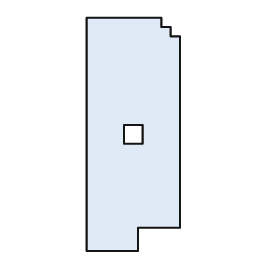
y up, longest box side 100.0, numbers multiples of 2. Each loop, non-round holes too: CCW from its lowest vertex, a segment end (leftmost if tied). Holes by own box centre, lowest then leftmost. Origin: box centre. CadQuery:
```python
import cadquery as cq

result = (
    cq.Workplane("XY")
    .moveTo(-20.0, -50.0)
    .lineTo(2.0, -50.0)
    .lineTo(2.0, -40.0)
    .lineTo(20.0, -40.0)
    .lineTo(20.0, 42.0)
    .lineTo(16.0, 42.0)
    .lineTo(16.0, 46.0)
    .lineTo(12.0, 46.0)
    .lineTo(12.0, 50.0)
    .lineTo(-20.0, 50.0)
    .close()
    .moveTo(-4.0, -4.0)
    .lineTo(4.0, -4.0)
    .lineTo(4.0, 4.0)
    .lineTo(-4.0, 4.0)
    .close()
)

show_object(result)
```